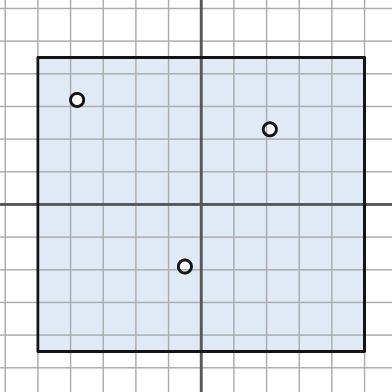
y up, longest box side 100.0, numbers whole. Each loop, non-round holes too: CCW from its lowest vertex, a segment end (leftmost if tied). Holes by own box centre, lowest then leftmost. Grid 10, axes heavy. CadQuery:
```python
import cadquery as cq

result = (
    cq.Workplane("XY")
    .moveTo(-50.0, -45.0)
    .lineTo(50.0, -45.0)
    .lineTo(50.0, 45.0)
    .lineTo(-50.0, 45.0)
    .close()
    .moveTo(-5.0, -19.0)
    .circle(2.0)
    .moveTo(21.0, 23.0)
    .circle(2.0)
    .moveTo(-38.0, 32.0)
    .circle(2.0)
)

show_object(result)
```